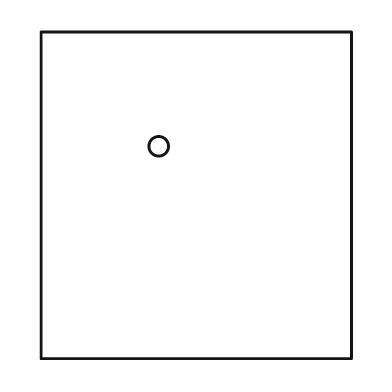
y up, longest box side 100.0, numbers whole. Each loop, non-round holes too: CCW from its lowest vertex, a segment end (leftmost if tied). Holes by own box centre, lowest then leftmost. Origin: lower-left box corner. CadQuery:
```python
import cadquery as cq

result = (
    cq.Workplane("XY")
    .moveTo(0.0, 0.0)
    .lineTo(95.0, 0.0)
    .lineTo(95.0, 100.0)
    .lineTo(0.0, 100.0)
    .close()
    .moveTo(36.0, 65.0)
    .circle(3.0)
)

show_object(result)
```